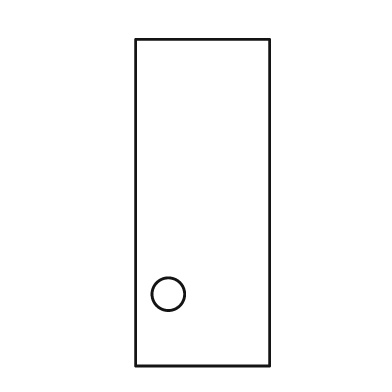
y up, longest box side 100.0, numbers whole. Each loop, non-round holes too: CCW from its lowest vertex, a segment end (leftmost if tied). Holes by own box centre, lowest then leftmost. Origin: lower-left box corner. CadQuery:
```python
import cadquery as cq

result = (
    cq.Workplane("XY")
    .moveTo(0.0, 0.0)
    .lineTo(41.0, 0.0)
    .lineTo(41.0, 100.0)
    .lineTo(0.0, 100.0)
    .close()
    .moveTo(10.0, 22.0)
    .circle(5.0)
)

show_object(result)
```